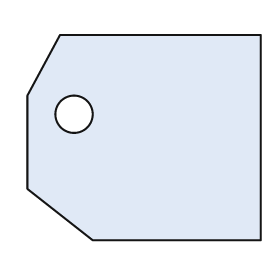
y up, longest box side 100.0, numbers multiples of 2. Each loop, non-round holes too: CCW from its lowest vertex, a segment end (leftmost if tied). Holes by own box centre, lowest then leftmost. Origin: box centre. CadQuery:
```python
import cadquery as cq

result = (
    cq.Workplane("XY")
    .moveTo(-22.0, -44.0)
    .lineTo(50.0, -44.0)
    .lineTo(50.0, 44.0)
    .lineTo(-36.0, 44.0)
    .lineTo(-50.0, 18.0)
    .lineTo(-50.0, -22.0)
    .close()
    .moveTo(-30.0, 10.0)
    .circle(8.0)
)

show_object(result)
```